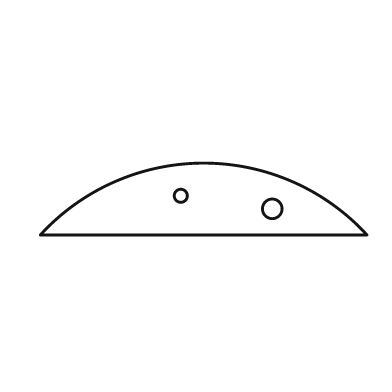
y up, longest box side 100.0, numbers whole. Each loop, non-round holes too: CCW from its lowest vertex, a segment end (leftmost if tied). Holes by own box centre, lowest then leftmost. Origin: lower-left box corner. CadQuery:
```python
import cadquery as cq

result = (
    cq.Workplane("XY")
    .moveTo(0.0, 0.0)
    .lineTo(100.0, 0.0)
    .threePointArc((50.0, 22.0), (0.0, 0.0))
    .close()
    .moveTo(71.0, 8.0)
    .circle(3.0)
    .moveTo(43.0, 12.0)
    .circle(2.0)
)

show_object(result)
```